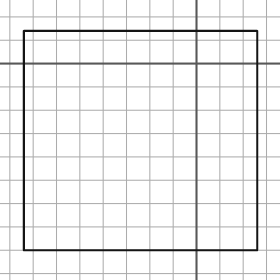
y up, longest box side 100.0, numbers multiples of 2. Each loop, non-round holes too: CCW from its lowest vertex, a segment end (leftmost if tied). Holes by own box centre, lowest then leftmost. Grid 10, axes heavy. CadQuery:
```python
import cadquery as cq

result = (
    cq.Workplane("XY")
    .moveTo(-74.0, -80.0)
    .lineTo(26.0, -80.0)
    .lineTo(26.0, 14.0)
    .lineTo(-74.0, 14.0)
    .close()
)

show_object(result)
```